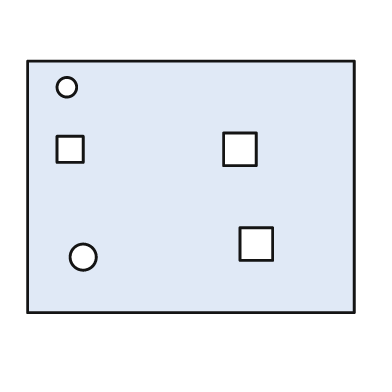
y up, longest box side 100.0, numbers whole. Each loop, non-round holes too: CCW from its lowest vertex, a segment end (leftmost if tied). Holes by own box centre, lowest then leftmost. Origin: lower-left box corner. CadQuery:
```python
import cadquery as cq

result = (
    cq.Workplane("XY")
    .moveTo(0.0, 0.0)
    .lineTo(100.0, 0.0)
    .lineTo(100.0, 77.0)
    .lineTo(0.0, 77.0)
    .close()
    .moveTo(17.0, 17.0)
    .circle(4.0)
    .moveTo(65.0, 16.0)
    .lineTo(75.0, 16.0)
    .lineTo(75.0, 26.0)
    .lineTo(65.0, 26.0)
    .close()
    .moveTo(9.0, 46.0)
    .lineTo(17.0, 46.0)
    .lineTo(17.0, 54.0)
    .lineTo(9.0, 54.0)
    .close()
    .moveTo(60.0, 45.0)
    .lineTo(70.0, 45.0)
    .lineTo(70.0, 55.0)
    .lineTo(60.0, 55.0)
    .close()
    .moveTo(12.0, 69.0)
    .circle(3.0)
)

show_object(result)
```